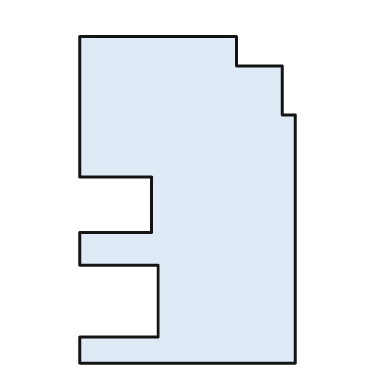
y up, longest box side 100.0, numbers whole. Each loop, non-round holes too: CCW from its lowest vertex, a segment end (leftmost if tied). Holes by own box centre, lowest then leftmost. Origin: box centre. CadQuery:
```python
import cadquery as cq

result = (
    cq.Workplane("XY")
    .moveTo(-33.0, -50.0)
    .lineTo(33.0, -50.0)
    .lineTo(33.0, 26.0)
    .lineTo(29.0, 26.0)
    .lineTo(29.0, 41.0)
    .lineTo(15.0, 41.0)
    .lineTo(15.0, 50.0)
    .lineTo(-33.0, 50.0)
    .lineTo(-33.0, 7.0)
    .lineTo(-11.0, 7.0)
    .lineTo(-11.0, -10.0)
    .lineTo(-33.0, -10.0)
    .lineTo(-33.0, -20.0)
    .lineTo(-9.0, -20.0)
    .lineTo(-9.0, -42.0)
    .lineTo(-33.0, -42.0)
    .close()
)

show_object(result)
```